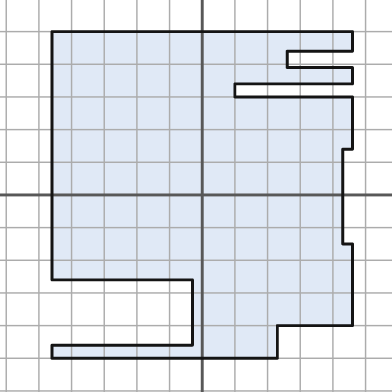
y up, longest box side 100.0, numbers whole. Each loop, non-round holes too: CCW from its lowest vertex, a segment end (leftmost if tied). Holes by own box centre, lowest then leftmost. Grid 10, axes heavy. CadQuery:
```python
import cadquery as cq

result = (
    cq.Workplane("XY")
    .moveTo(-46.0, -50.0)
    .lineTo(23.0, -50.0)
    .lineTo(23.0, -40.0)
    .lineTo(46.0, -40.0)
    .lineTo(46.0, -15.0)
    .lineTo(43.0, -15.0)
    .lineTo(43.0, 14.0)
    .lineTo(46.0, 14.0)
    .lineTo(46.0, 30.0)
    .lineTo(10.0, 30.0)
    .lineTo(10.0, 34.0)
    .lineTo(46.0, 34.0)
    .lineTo(46.0, 39.0)
    .lineTo(26.0, 39.0)
    .lineTo(26.0, 44.0)
    .lineTo(46.0, 44.0)
    .lineTo(46.0, 50.0)
    .lineTo(-46.0, 50.0)
    .lineTo(-46.0, -26.0)
    .lineTo(-3.0, -26.0)
    .lineTo(-3.0, -46.0)
    .lineTo(-46.0, -46.0)
    .close()
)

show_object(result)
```